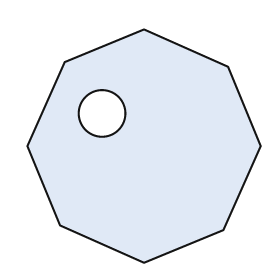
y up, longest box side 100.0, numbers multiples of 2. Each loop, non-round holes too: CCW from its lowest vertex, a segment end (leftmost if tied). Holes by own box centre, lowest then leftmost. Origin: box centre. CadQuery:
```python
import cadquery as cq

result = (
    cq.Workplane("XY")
    .moveTo(0.0, -50.0)
    .lineTo(34.0, -36.0)
    .lineTo(50.0, 0.0)
    .lineTo(36.0, 34.0)
    .lineTo(0.0, 50.0)
    .lineTo(-34.0, 36.0)
    .lineTo(-50.0, 0.0)
    .lineTo(-36.0, -34.0)
    .close()
    .moveTo(-18.0, 14.0)
    .circle(10.0)
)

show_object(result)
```